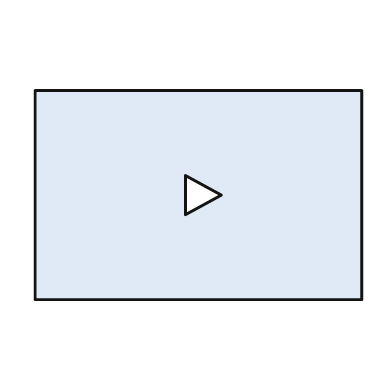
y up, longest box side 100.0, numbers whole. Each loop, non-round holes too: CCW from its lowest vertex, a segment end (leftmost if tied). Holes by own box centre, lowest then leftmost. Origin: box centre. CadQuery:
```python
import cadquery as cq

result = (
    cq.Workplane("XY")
    .moveTo(-50.0, -32.0)
    .lineTo(50.0, -32.0)
    .lineTo(50.0, 32.0)
    .lineTo(-50.0, 32.0)
    .close()
    .moveTo(-4.0, -6.0)
    .lineTo(7.0, 0.0)
    .lineTo(-4.0, 6.0)
    .close()
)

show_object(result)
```